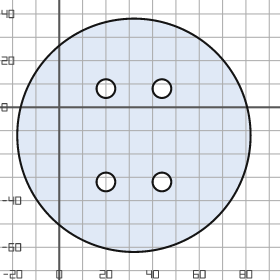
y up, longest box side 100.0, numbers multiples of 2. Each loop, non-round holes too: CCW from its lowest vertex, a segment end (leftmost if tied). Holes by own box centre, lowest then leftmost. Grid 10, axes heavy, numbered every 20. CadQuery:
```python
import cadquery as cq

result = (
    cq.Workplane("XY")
    .moveTo(32.0, -12.0)
    .circle(50.0)
    .moveTo(20.0, -32.0)
    .circle(4.0)
    .moveTo(44.0, -32.0)
    .circle(4.0)
    .moveTo(20.0, 8.0)
    .circle(4.0)
    .moveTo(44.0, 8.0)
    .circle(4.0)
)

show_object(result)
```